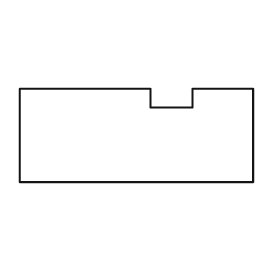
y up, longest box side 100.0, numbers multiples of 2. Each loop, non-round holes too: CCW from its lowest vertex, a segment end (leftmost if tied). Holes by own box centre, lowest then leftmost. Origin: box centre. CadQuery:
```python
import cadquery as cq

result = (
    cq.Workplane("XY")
    .moveTo(-50.0, -20.0)
    .lineTo(50.0, -20.0)
    .lineTo(50.0, 20.0)
    .lineTo(24.0, 20.0)
    .lineTo(24.0, 12.0)
    .lineTo(6.0, 12.0)
    .lineTo(6.0, 20.0)
    .lineTo(-50.0, 20.0)
    .close()
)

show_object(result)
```